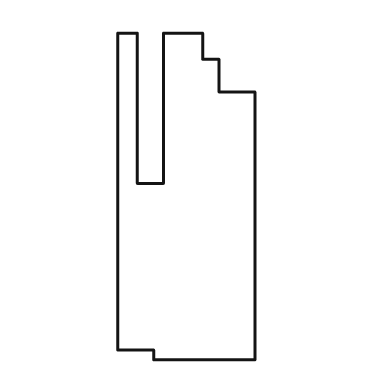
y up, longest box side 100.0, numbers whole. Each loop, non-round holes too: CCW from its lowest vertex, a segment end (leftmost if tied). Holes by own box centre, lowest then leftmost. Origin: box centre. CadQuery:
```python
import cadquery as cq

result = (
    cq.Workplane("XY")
    .moveTo(-10.0, -50.0)
    .lineTo(21.0, -50.0)
    .lineTo(21.0, 32.0)
    .lineTo(10.0, 32.0)
    .lineTo(10.0, 42.0)
    .lineTo(5.0, 42.0)
    .lineTo(5.0, 50.0)
    .lineTo(-7.0, 50.0)
    .lineTo(-7.0, 4.0)
    .lineTo(-15.0, 4.0)
    .lineTo(-15.0, 50.0)
    .lineTo(-21.0, 50.0)
    .lineTo(-21.0, -47.0)
    .lineTo(-10.0, -47.0)
    .close()
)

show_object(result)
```